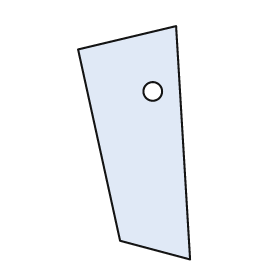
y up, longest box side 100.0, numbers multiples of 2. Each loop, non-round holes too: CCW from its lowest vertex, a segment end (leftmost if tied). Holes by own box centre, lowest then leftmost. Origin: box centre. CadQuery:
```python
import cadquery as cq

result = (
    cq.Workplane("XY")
    .moveTo(24.0, -50.0)
    .lineTo(18.0, 50.0)
    .lineTo(-24.0, 40.0)
    .lineTo(-6.0, -42.0)
    .close()
    .moveTo(8.0, 22.0)
    .circle(4.0)
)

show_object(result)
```